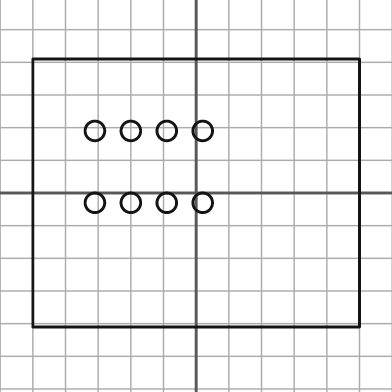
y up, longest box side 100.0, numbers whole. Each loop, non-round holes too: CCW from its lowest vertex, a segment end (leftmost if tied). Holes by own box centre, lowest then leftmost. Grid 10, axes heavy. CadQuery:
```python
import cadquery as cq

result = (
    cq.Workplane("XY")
    .moveTo(-50.0, -41.0)
    .lineTo(50.0, -41.0)
    .lineTo(50.0, 41.0)
    .lineTo(-50.0, 41.0)
    .close()
    .moveTo(-31.0, -3.0)
    .circle(3.0)
    .moveTo(-20.0, -3.0)
    .circle(3.0)
    .moveTo(-9.0, -3.0)
    .circle(3.0)
    .moveTo(2.0, -3.0)
    .circle(3.0)
    .moveTo(-31.0, 19.0)
    .circle(3.0)
    .moveTo(-20.0, 19.0)
    .circle(3.0)
    .moveTo(-9.0, 19.0)
    .circle(3.0)
    .moveTo(2.0, 19.0)
    .circle(3.0)
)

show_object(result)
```